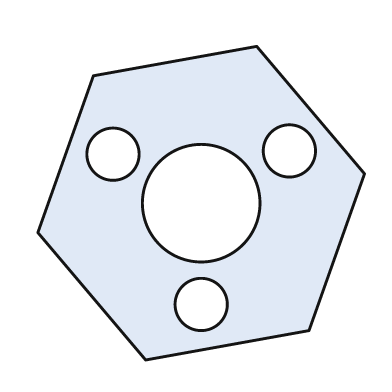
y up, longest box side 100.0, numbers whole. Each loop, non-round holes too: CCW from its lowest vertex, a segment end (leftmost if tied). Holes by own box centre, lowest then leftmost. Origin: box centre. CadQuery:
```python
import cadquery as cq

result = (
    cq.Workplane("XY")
    .moveTo(-17.0, -48.0)
    .lineTo(33.0, -39.0)
    .lineTo(50.0, 9.0)
    .lineTo(17.0, 48.0)
    .lineTo(-33.0, 39.0)
    .lineTo(-50.0, -9.0)
    .close()
    .moveTo(0.0, -31.0)
    .circle(8.0)
    .moveTo(0.0, 0.0)
    .circle(18.0)
    .moveTo(-27.0, 15.0)
    .circle(8.0)
    .moveTo(27.0, 16.0)
    .circle(8.0)
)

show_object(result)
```